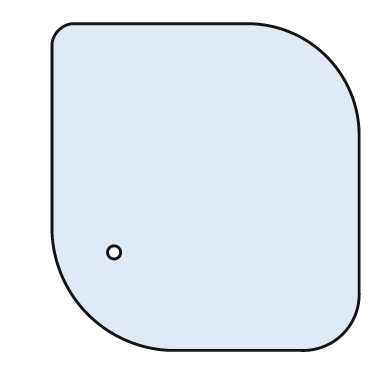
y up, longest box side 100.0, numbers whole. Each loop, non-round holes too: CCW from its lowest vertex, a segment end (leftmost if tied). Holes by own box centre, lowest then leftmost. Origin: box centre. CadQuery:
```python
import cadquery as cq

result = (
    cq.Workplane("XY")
    .moveTo(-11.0, -50.0)
    .lineTo(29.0, -50.0)
    .threePointArc((42.0, -45.0), (47.0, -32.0))
    .lineTo(47.0, 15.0)
    .threePointArc((37.0, 40.0), (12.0, 50.0))
    .lineTo(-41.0, 50.0)
    .threePointArc((-45.0, 48.0), (-47.0, 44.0))
    .lineTo(-47.0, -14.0)
    .threePointArc((-36.0, -39.0), (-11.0, -50.0))
    .close()
    .moveTo(-28.0, -20.0)
    .circle(2.0)
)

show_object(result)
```